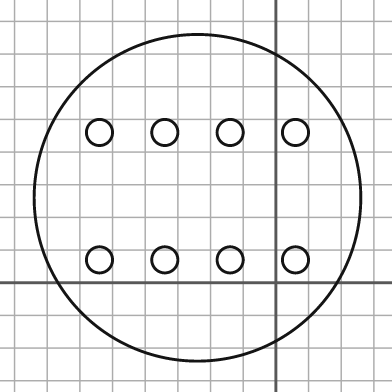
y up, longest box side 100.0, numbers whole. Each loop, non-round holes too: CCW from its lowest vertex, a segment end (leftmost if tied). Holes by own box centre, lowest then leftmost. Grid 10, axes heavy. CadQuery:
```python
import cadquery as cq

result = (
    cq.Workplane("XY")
    .moveTo(-24.0, 26.0)
    .circle(50.0)
    .moveTo(-54.0, 7.0)
    .circle(4.0)
    .moveTo(-34.0, 7.0)
    .circle(4.0)
    .moveTo(-14.0, 7.0)
    .circle(4.0)
    .moveTo(6.0, 7.0)
    .circle(4.0)
    .moveTo(-54.0, 46.0)
    .circle(4.0)
    .moveTo(-34.0, 46.0)
    .circle(4.0)
    .moveTo(-14.0, 46.0)
    .circle(4.0)
    .moveTo(6.0, 46.0)
    .circle(4.0)
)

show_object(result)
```